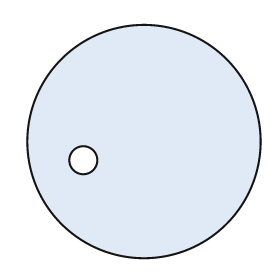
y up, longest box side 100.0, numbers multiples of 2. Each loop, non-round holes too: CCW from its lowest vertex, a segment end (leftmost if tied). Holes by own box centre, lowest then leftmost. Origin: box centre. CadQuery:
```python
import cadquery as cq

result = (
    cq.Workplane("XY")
    .moveTo(0.0, 0.0)
    .circle(50.0)
    .moveTo(-26.0, -8.0)
    .circle(6.0)
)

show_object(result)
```